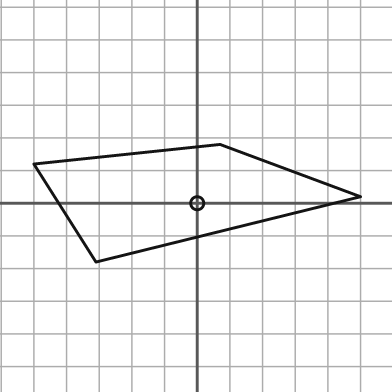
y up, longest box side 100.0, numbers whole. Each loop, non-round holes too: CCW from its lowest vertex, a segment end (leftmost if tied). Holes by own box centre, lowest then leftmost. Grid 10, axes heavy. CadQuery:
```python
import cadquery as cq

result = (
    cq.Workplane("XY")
    .moveTo(-31.0, -18.0)
    .lineTo(50.0, 2.0)
    .lineTo(7.0, 18.0)
    .lineTo(-50.0, 12.0)
    .close()
    .moveTo(0.0, 0.0)
    .circle(2.0)
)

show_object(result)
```